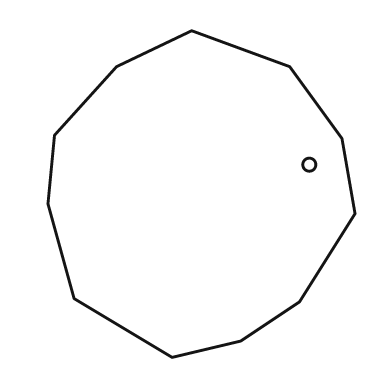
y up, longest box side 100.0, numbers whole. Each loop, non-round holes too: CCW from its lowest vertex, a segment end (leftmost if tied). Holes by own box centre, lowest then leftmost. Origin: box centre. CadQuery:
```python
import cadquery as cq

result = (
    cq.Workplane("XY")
    .moveTo(-9.0, -50.0)
    .lineTo(12.0, -45.0)
    .lineTo(30.0, -33.0)
    .lineTo(47.0, -6.0)
    .lineTo(43.0, 17.0)
    .lineTo(27.0, 39.0)
    .lineTo(-3.0, 50.0)
    .lineTo(-26.0, 39.0)
    .lineTo(-45.0, 18.0)
    .lineTo(-47.0, -3.0)
    .lineTo(-39.0, -32.0)
    .close()
    .moveTo(33.0, 9.0)
    .circle(2.0)
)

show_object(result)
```